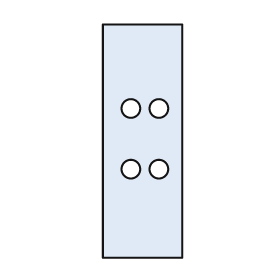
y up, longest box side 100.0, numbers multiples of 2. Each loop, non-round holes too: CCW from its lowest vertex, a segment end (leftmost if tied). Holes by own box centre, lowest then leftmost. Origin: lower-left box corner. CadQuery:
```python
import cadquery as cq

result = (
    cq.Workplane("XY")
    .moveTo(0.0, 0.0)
    .lineTo(34.0, 0.0)
    .lineTo(34.0, 100.0)
    .lineTo(0.0, 100.0)
    .close()
    .moveTo(12.0, 38.0)
    .circle(4.0)
    .moveTo(24.0, 38.0)
    .circle(4.0)
    .moveTo(12.0, 64.0)
    .circle(4.0)
    .moveTo(24.0, 64.0)
    .circle(4.0)
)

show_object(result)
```